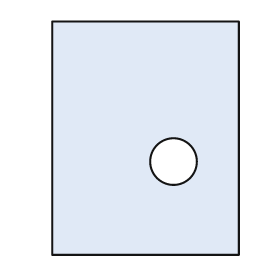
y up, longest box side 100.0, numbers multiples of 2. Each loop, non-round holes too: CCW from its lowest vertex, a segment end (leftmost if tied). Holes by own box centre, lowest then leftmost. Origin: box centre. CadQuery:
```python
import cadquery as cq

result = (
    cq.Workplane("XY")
    .moveTo(-40.0, -50.0)
    .lineTo(40.0, -50.0)
    .lineTo(40.0, 50.0)
    .lineTo(-40.0, 50.0)
    .close()
    .moveTo(12.0, -10.0)
    .circle(10.0)
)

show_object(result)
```